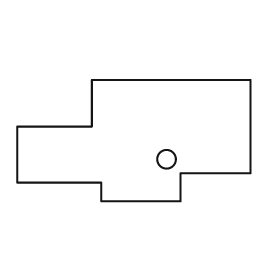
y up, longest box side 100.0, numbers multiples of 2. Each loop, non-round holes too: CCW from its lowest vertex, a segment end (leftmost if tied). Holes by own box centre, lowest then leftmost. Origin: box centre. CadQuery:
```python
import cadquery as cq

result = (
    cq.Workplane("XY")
    .moveTo(-14.0, -26.0)
    .lineTo(20.0, -26.0)
    .lineTo(20.0, -14.0)
    .lineTo(50.0, -14.0)
    .lineTo(50.0, 26.0)
    .lineTo(-18.0, 26.0)
    .lineTo(-18.0, 6.0)
    .lineTo(-50.0, 6.0)
    .lineTo(-50.0, -18.0)
    .lineTo(-14.0, -18.0)
    .close()
    .moveTo(14.0, -8.0)
    .circle(4.0)
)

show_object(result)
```